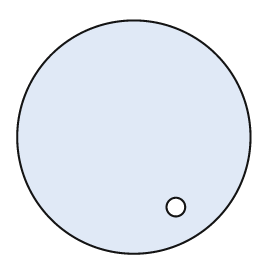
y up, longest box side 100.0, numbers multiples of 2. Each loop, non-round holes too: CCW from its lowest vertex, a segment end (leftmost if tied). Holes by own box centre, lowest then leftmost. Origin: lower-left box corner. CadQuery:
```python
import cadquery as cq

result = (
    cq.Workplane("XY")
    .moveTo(50.0, 50.0)
    .circle(50.0)
    .moveTo(68.0, 20.0)
    .circle(4.0)
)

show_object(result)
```